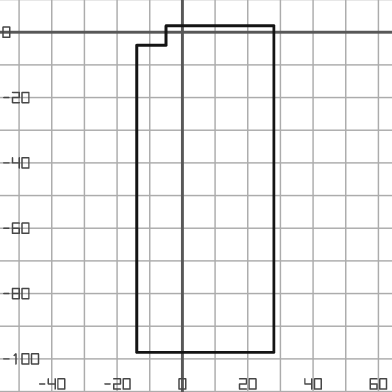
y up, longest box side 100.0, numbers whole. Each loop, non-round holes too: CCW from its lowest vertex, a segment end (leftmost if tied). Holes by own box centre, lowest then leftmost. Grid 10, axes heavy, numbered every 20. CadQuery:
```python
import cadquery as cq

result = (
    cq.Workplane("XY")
    .moveTo(-14.0, -98.0)
    .lineTo(28.0, -98.0)
    .lineTo(28.0, 2.0)
    .lineTo(-5.0, 2.0)
    .lineTo(-5.0, -4.0)
    .lineTo(-14.0, -4.0)
    .close()
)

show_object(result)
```